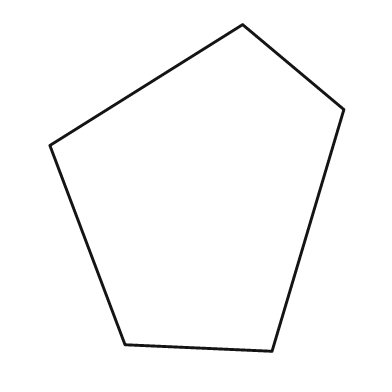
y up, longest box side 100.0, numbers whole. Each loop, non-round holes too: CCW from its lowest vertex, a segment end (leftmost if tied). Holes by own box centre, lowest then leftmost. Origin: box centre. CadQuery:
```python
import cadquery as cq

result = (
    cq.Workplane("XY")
    .moveTo(23.0, -50.0)
    .lineTo(45.0, 24.0)
    .lineTo(14.0, 50.0)
    .lineTo(-45.0, 13.0)
    .lineTo(-22.0, -48.0)
    .close()
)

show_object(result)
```